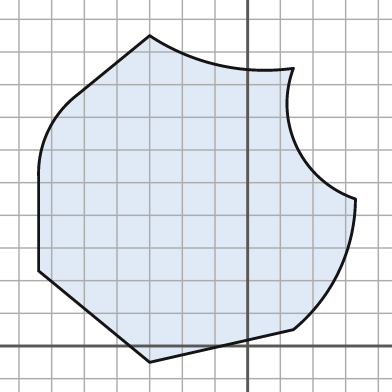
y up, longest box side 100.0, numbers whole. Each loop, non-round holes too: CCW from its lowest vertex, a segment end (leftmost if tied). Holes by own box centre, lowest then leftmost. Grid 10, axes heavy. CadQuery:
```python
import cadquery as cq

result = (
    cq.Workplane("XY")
    .moveTo(-30.0, -5.0)
    .lineTo(14.0, 5.0)
    .threePointArc((28.0, 23.0), (33.0, 45.0))
    .threePointArc((15.0, 61.0), (14.0, 85.0))
    .threePointArc((-9.0, 86.0), (-30.0, 95.0))
    .lineTo(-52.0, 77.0)
    .threePointArc((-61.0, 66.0), (-64.0, 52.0))
    .lineTo(-64.0, 23.0)
    .close()
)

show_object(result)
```